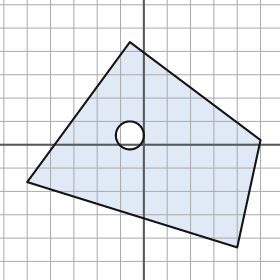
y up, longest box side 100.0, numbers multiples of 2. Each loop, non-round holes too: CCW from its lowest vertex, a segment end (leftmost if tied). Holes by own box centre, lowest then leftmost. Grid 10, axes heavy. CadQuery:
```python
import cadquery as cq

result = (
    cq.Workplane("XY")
    .moveTo(40.0, -44.0)
    .lineTo(50.0, 2.0)
    .lineTo(-6.0, 44.0)
    .lineTo(-50.0, -16.0)
    .close()
    .moveTo(-6.0, 4.0)
    .circle(6.0)
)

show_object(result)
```